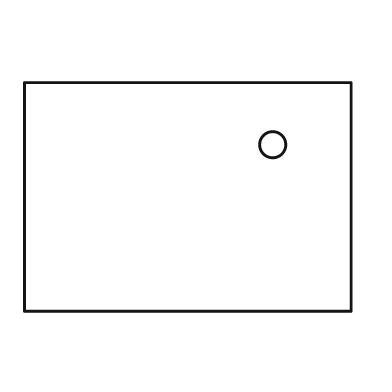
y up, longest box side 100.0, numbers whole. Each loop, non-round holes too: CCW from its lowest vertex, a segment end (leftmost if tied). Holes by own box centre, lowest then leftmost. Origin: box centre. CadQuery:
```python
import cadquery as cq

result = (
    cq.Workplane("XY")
    .moveTo(-50.0, -35.0)
    .lineTo(50.0, -35.0)
    .lineTo(50.0, 35.0)
    .lineTo(-50.0, 35.0)
    .close()
    .moveTo(26.0, 16.0)
    .circle(4.0)
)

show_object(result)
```